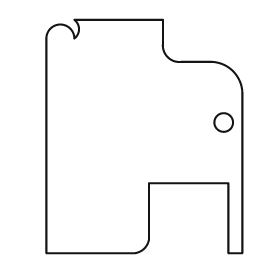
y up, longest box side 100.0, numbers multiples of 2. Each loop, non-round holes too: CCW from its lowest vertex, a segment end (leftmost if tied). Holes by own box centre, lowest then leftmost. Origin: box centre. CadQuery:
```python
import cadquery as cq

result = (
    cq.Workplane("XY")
    .moveTo(-42.0, -50.0)
    .lineTo(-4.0, -50.0)
    .threePointArc((0.0, -48.0), (2.0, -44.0))
    .lineTo(2.0, -20.0)
    .lineTo(36.0, -20.0)
    .lineTo(36.0, -50.0)
    .lineTo(42.0, -50.0)
    .lineTo(42.0, 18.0)
    .threePointArc((38.0, 28.0), (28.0, 32.0))
    .lineTo(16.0, 32.0)
    .threePointArc((10.0, 34.0), (8.0, 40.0))
    .lineTo(8.0, 50.0)
    .lineTo(-30.0, 50.0)
    .threePointArc((-28.0, 46.0), (-30.0, 42.0))
    .threePointArc((-36.0, 48.0), (-42.0, 42.0))
    .close()
    .moveTo(34.0, 6.0)
    .circle(4.0)
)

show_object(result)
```